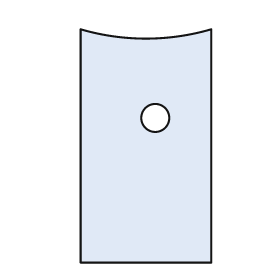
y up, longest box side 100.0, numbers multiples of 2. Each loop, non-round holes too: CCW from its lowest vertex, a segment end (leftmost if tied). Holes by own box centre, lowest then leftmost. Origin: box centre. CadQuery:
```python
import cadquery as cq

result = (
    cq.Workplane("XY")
    .moveTo(-28.0, -50.0)
    .lineTo(28.0, -50.0)
    .lineTo(28.0, 50.0)
    .threePointArc((0.0, 46.0), (-28.0, 50.0))
    .close()
    .moveTo(4.0, 12.0)
    .circle(6.0)
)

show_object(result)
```